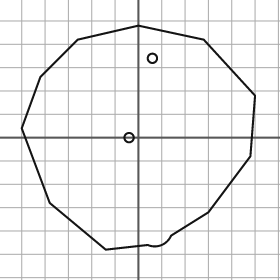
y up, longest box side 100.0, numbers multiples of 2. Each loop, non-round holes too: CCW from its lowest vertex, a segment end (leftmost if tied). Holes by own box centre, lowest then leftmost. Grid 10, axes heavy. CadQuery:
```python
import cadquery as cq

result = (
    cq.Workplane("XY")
    .moveTo(-14.0, -48.0)
    .lineTo(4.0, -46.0)
    .threePointArc((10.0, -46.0), (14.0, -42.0))
    .lineTo(30.0, -32.0)
    .lineTo(48.0, -8.0)
    .lineTo(50.0, 18.0)
    .lineTo(28.0, 42.0)
    .lineTo(0.0, 48.0)
    .lineTo(-26.0, 42.0)
    .lineTo(-42.0, 26.0)
    .lineTo(-50.0, 4.0)
    .lineTo(-38.0, -28.0)
    .close()
    .moveTo(-4.0, 0.0)
    .circle(2.0)
    .moveTo(6.0, 34.0)
    .circle(2.0)
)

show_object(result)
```